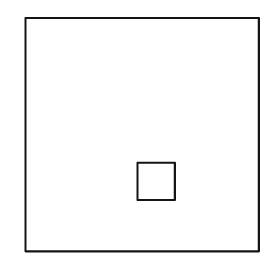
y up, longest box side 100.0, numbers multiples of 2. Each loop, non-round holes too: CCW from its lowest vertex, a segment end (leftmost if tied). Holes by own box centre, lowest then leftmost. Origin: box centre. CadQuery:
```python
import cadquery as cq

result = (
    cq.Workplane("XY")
    .moveTo(-50.0, -50.0)
    .lineTo(50.0, -50.0)
    .lineTo(50.0, 50.0)
    .lineTo(-50.0, 50.0)
    .close()
    .moveTo(-2.0, -28.0)
    .lineTo(14.0, -28.0)
    .lineTo(14.0, -12.0)
    .lineTo(-2.0, -12.0)
    .close()
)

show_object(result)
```